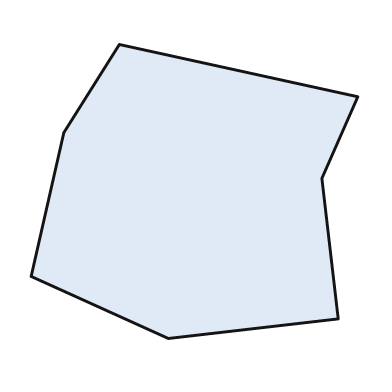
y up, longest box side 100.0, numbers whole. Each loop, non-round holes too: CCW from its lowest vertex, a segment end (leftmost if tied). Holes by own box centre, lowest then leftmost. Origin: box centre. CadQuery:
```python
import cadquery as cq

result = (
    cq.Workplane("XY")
    .moveTo(-8.0, -45.0)
    .lineTo(44.0, -39.0)
    .lineTo(39.0, 4.0)
    .lineTo(50.0, 29.0)
    .lineTo(-23.0, 45.0)
    .lineTo(-40.0, 18.0)
    .lineTo(-50.0, -26.0)
    .close()
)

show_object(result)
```